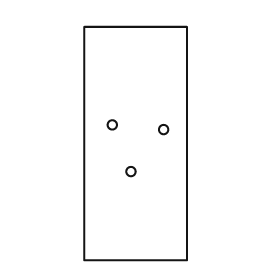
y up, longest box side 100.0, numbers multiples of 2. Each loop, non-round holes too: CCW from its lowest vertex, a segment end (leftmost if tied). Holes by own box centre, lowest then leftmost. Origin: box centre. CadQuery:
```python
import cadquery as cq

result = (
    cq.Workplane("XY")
    .moveTo(-22.0, -50.0)
    .lineTo(22.0, -50.0)
    .lineTo(22.0, 50.0)
    .lineTo(-22.0, 50.0)
    .close()
    .moveTo(-2.0, -12.0)
    .circle(2.0)
    .moveTo(12.0, 6.0)
    .circle(2.0)
    .moveTo(-10.0, 8.0)
    .circle(2.0)
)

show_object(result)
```